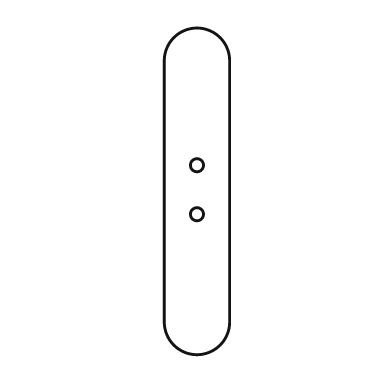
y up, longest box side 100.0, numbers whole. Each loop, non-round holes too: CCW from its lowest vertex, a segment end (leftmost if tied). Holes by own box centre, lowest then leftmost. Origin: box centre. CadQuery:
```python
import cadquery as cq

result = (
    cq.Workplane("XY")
    .moveTo(-10.0, -40.0)
    .threePointArc((0.0, -50.0), (10.0, -40.0))
    .lineTo(10.0, 40.0)
    .threePointArc((0.0, 50.0), (-10.0, 40.0))
    .close()
    .moveTo(0.0, -7.0)
    .circle(2.0)
    .moveTo(0.0, 8.0)
    .circle(2.0)
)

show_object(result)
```